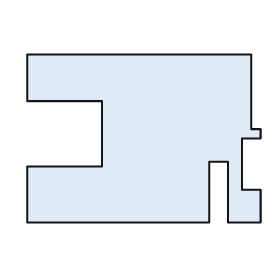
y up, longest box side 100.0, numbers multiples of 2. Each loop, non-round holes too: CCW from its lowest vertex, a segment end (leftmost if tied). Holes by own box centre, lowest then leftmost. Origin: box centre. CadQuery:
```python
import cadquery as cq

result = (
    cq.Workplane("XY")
    .moveTo(-50.0, -36.0)
    .lineTo(28.0, -36.0)
    .lineTo(28.0, -10.0)
    .lineTo(36.0, -10.0)
    .lineTo(36.0, -36.0)
    .lineTo(50.0, -36.0)
    .lineTo(50.0, -22.0)
    .lineTo(42.0, -22.0)
    .lineTo(42.0, 0.0)
    .lineTo(50.0, 0.0)
    .lineTo(50.0, 4.0)
    .lineTo(46.0, 4.0)
    .lineTo(46.0, 36.0)
    .lineTo(-50.0, 36.0)
    .lineTo(-50.0, 16.0)
    .lineTo(-18.0, 16.0)
    .lineTo(-18.0, -12.0)
    .lineTo(-50.0, -12.0)
    .close()
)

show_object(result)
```